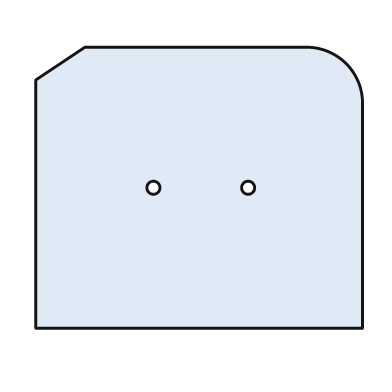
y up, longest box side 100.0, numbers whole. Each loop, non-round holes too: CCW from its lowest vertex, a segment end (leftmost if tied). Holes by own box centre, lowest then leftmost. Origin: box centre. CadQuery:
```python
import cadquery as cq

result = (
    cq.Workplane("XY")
    .moveTo(-50.0, -43.0)
    .lineTo(50.0, -43.0)
    .lineTo(50.0, 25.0)
    .threePointArc((45.0, 38.0), (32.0, 43.0))
    .lineTo(-35.0, 43.0)
    .lineTo(-50.0, 33.0)
    .close()
    .moveTo(-14.0, 0.0)
    .circle(2.0)
    .moveTo(15.0, 0.0)
    .circle(2.0)
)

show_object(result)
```